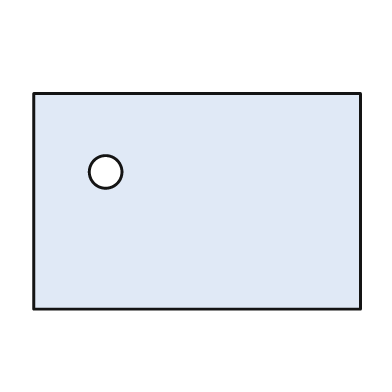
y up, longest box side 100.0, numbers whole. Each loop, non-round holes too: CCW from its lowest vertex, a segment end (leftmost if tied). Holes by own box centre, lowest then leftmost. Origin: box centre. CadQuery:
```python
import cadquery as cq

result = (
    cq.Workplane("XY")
    .moveTo(-50.0, -33.0)
    .lineTo(50.0, -33.0)
    .lineTo(50.0, 33.0)
    .lineTo(-50.0, 33.0)
    .close()
    .moveTo(-28.0, 9.0)
    .circle(5.0)
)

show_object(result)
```